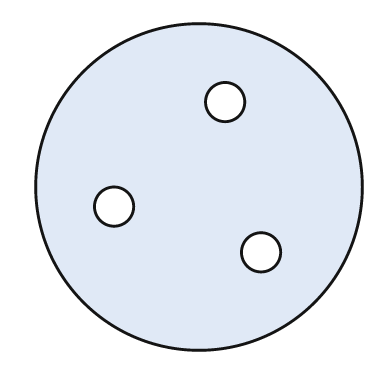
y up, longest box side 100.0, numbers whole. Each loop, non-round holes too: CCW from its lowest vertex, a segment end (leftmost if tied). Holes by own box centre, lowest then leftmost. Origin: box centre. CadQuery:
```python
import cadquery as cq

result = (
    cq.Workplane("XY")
    .moveTo(0.0, 0.0)
    .circle(50.0)
    .moveTo(19.0, -20.0)
    .circle(6.0)
    .moveTo(-26.0, -6.0)
    .circle(6.0)
    .moveTo(8.0, 26.0)
    .circle(6.0)
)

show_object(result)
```